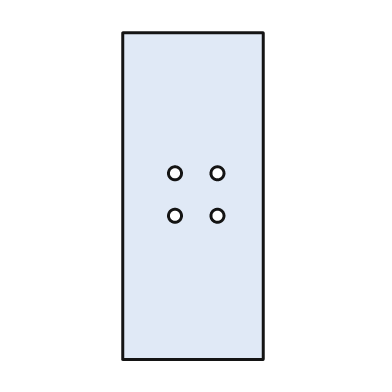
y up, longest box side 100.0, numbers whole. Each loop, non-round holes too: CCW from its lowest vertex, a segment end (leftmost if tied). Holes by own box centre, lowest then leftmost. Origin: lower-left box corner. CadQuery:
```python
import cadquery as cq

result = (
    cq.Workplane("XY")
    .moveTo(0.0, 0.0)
    .lineTo(43.0, 0.0)
    .lineTo(43.0, 100.0)
    .lineTo(0.0, 100.0)
    .close()
    .moveTo(16.0, 44.0)
    .circle(2.0)
    .moveTo(29.0, 44.0)
    .circle(2.0)
    .moveTo(16.0, 57.0)
    .circle(2.0)
    .moveTo(29.0, 57.0)
    .circle(2.0)
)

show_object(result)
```